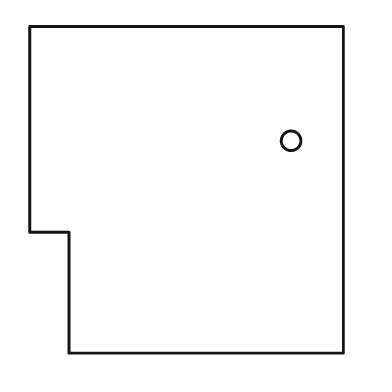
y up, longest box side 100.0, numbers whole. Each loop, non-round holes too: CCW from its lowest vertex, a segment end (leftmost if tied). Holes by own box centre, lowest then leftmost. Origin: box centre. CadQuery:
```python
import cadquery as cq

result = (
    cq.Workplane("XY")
    .moveTo(-36.0, -50.0)
    .lineTo(48.0, -50.0)
    .lineTo(48.0, 50.0)
    .lineTo(-48.0, 50.0)
    .lineTo(-48.0, -13.0)
    .lineTo(-36.0, -13.0)
    .close()
    .moveTo(32.0, 15.0)
    .circle(3.0)
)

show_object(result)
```